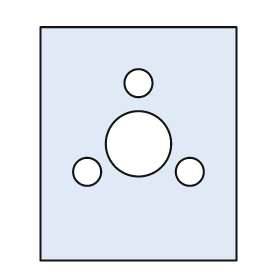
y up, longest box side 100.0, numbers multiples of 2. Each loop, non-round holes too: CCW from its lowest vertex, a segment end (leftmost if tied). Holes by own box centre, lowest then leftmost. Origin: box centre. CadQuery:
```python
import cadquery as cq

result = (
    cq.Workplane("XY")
    .moveTo(-42.0, -50.0)
    .lineTo(42.0, -50.0)
    .lineTo(42.0, 50.0)
    .lineTo(-42.0, 50.0)
    .close()
    .moveTo(-22.0, -12.0)
    .circle(6.0)
    .moveTo(22.0, -12.0)
    .circle(6.0)
    .moveTo(0.0, 0.0)
    .circle(14.0)
    .moveTo(0.0, 26.0)
    .circle(6.0)
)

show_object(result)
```